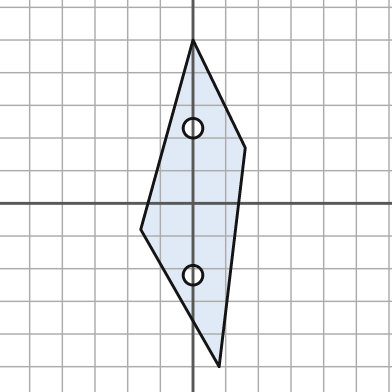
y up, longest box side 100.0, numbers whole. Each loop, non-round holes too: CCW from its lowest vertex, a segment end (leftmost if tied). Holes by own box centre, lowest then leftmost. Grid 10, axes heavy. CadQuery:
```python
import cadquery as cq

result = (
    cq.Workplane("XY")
    .moveTo(8.0, -50.0)
    .lineTo(16.0, 17.0)
    .lineTo(0.0, 50.0)
    .lineTo(-16.0, -8.0)
    .close()
    .moveTo(0.0, -22.0)
    .circle(3.0)
    .moveTo(0.0, 23.0)
    .circle(3.0)
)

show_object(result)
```